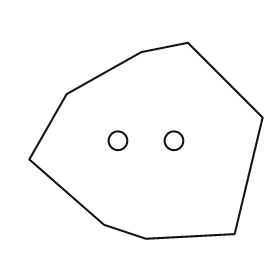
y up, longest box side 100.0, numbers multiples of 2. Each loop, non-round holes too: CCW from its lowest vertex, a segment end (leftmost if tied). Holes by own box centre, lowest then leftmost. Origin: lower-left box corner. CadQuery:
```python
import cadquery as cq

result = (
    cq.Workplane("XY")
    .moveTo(50.0, 0.0)
    .lineTo(88.0, 2.0)
    .lineTo(100.0, 52.0)
    .lineTo(68.0, 84.0)
    .lineTo(48.0, 80.0)
    .lineTo(16.0, 62.0)
    .lineTo(0.0, 34.0)
    .lineTo(32.0, 6.0)
    .close()
    .moveTo(38.0, 42.0)
    .circle(4.0)
    .moveTo(62.0, 42.0)
    .circle(4.0)
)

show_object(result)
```